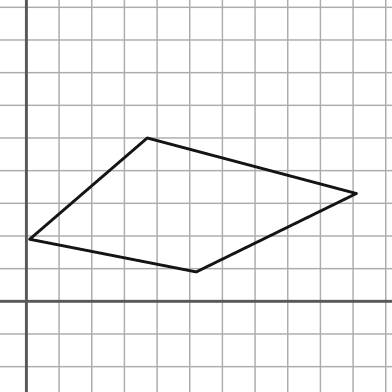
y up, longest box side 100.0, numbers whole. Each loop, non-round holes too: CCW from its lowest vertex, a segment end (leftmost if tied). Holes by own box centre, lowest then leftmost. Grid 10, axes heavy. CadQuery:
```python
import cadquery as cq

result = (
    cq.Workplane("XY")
    .moveTo(52.0, 9.0)
    .lineTo(101.0, 33.0)
    .lineTo(37.0, 50.0)
    .lineTo(1.0, 19.0)
    .close()
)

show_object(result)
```